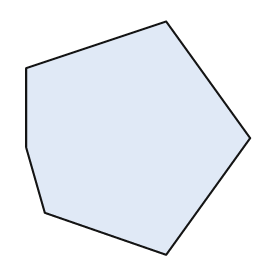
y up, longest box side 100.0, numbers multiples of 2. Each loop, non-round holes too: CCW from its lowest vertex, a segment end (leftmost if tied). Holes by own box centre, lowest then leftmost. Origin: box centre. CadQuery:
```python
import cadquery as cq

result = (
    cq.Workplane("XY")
    .moveTo(12.0, -50.0)
    .lineTo(48.0, 0.0)
    .lineTo(12.0, 50.0)
    .lineTo(-48.0, 30.0)
    .lineTo(-48.0, -4.0)
    .lineTo(-40.0, -32.0)
    .close()
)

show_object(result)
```